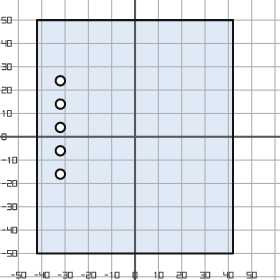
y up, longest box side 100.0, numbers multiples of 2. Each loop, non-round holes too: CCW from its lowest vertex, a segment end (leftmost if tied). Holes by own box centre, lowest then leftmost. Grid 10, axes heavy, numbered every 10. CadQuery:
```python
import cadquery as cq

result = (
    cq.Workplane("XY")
    .moveTo(-42.0, -50.0)
    .lineTo(42.0, -50.0)
    .lineTo(42.0, 50.0)
    .lineTo(-42.0, 50.0)
    .close()
    .moveTo(-32.0, -16.0)
    .circle(2.0)
    .moveTo(-32.0, -6.0)
    .circle(2.0)
    .moveTo(-32.0, 4.0)
    .circle(2.0)
    .moveTo(-32.0, 14.0)
    .circle(2.0)
    .moveTo(-32.0, 24.0)
    .circle(2.0)
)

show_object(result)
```